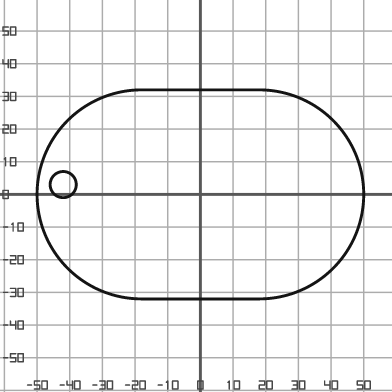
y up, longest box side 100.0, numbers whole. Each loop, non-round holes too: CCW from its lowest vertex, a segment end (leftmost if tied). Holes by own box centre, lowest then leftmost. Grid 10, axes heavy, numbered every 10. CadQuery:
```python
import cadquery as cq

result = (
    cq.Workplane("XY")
    .moveTo(-18.0, -32.0)
    .lineTo(18.0, -32.0)
    .threePointArc((50.0, 0.0), (18.0, 32.0))
    .lineTo(-18.0, 32.0)
    .threePointArc((-50.0, 0.0), (-18.0, -32.0))
    .close()
    .moveTo(-42.0, 3.0)
    .circle(4.0)
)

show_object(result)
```